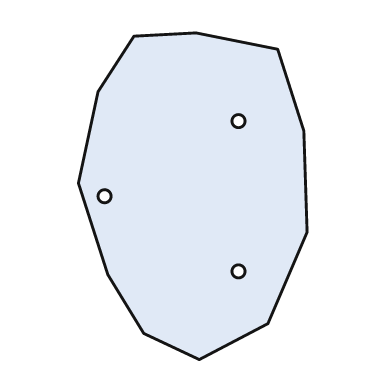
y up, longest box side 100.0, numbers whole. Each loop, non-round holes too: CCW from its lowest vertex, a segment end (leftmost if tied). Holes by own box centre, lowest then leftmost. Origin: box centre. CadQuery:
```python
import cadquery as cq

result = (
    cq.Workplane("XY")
    .moveTo(2.0, -50.0)
    .lineTo(23.0, -39.0)
    .lineTo(35.0, -11.0)
    .lineTo(34.0, 20.0)
    .lineTo(26.0, 45.0)
    .lineTo(1.0, 50.0)
    .lineTo(-18.0, 49.0)
    .lineTo(-29.0, 32.0)
    .lineTo(-35.0, 4.0)
    .lineTo(-26.0, -24.0)
    .lineTo(-15.0, -42.0)
    .close()
    .moveTo(14.0, -23.0)
    .circle(2.0)
    .moveTo(-27.0, 0.0)
    .circle(2.0)
    .moveTo(14.0, 23.0)
    .circle(2.0)
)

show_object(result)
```